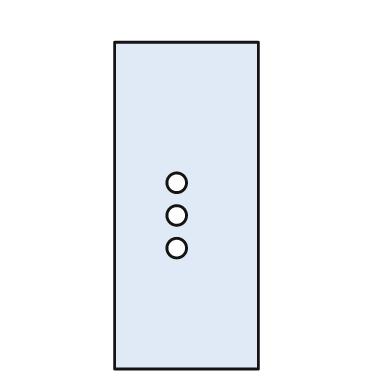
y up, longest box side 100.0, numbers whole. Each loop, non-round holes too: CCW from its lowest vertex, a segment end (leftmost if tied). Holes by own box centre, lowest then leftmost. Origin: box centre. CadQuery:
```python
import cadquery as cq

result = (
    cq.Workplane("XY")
    .moveTo(-22.0, -50.0)
    .lineTo(22.0, -50.0)
    .lineTo(22.0, 50.0)
    .lineTo(-22.0, 50.0)
    .close()
    .moveTo(-3.0, -13.0)
    .circle(3.0)
    .moveTo(-3.0, -3.0)
    .circle(3.0)
    .moveTo(-3.0, 7.0)
    .circle(3.0)
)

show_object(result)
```